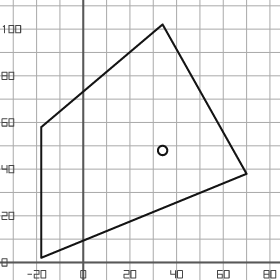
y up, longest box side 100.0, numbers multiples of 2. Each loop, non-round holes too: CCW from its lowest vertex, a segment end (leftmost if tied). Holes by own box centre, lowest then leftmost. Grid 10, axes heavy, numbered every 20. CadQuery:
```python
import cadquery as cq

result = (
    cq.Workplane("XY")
    .moveTo(-18.0, 2.0)
    .lineTo(70.0, 38.0)
    .lineTo(34.0, 102.0)
    .lineTo(-18.0, 58.0)
    .close()
    .moveTo(34.0, 48.0)
    .circle(2.0)
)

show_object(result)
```